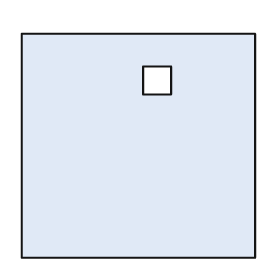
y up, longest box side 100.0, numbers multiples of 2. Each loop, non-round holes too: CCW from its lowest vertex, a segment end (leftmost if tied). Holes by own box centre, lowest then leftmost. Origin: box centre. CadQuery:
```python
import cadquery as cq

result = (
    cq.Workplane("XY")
    .moveTo(-50.0, -48.0)
    .lineTo(50.0, -48.0)
    .lineTo(50.0, 48.0)
    .lineTo(-50.0, 48.0)
    .close()
    .moveTo(2.0, 22.0)
    .lineTo(14.0, 22.0)
    .lineTo(14.0, 34.0)
    .lineTo(2.0, 34.0)
    .close()
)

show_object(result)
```